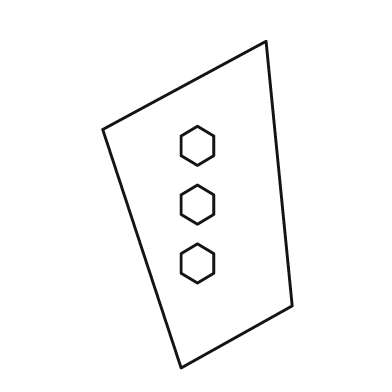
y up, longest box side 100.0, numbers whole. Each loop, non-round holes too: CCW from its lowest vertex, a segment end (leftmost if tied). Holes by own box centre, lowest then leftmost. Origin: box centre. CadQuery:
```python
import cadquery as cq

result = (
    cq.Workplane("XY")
    .moveTo(-5.0, -50.0)
    .lineTo(29.0, -31.0)
    .lineTo(21.0, 50.0)
    .lineTo(-29.0, 23.0)
    .close()
    .moveTo(0.0, -24.0)
    .lineTo(5.0, -21.0)
    .lineTo(5.0, -15.0)
    .lineTo(0.0, -12.0)
    .lineTo(-5.0, -15.0)
    .lineTo(-5.0, -21.0)
    .close()
    .moveTo(0.0, -6.0)
    .lineTo(5.0, -3.0)
    .lineTo(5.0, 3.0)
    .lineTo(0.0, 6.0)
    .lineTo(-5.0, 3.0)
    .lineTo(-5.0, -3.0)
    .close()
    .moveTo(0.0, 12.0)
    .lineTo(5.0, 15.0)
    .lineTo(5.0, 21.0)
    .lineTo(0.0, 24.0)
    .lineTo(-5.0, 21.0)
    .lineTo(-5.0, 15.0)
    .close()
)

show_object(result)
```